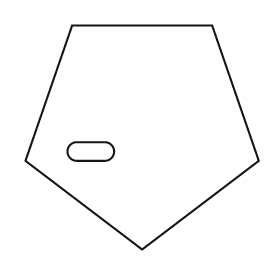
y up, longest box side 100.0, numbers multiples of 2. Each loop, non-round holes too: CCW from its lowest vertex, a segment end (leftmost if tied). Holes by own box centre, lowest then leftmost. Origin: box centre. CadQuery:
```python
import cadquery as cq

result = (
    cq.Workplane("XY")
    .moveTo(0.0, -48.0)
    .lineTo(50.0, -10.0)
    .lineTo(30.0, 48.0)
    .lineTo(-30.0, 48.0)
    .lineTo(-50.0, -10.0)
    .close()
    .moveTo(-28.0, -10.0)
    .lineTo(-16.0, -10.0)
    .threePointArc((-12.0, -6.0), (-16.0, -2.0))
    .lineTo(-28.0, -2.0)
    .threePointArc((-32.0, -6.0), (-28.0, -10.0))
    .close()
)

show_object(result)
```